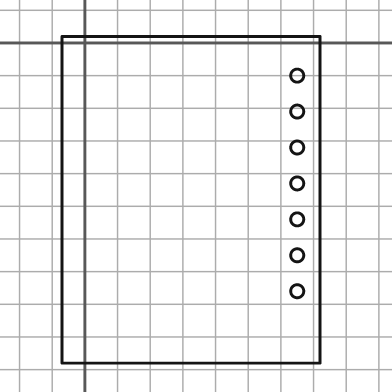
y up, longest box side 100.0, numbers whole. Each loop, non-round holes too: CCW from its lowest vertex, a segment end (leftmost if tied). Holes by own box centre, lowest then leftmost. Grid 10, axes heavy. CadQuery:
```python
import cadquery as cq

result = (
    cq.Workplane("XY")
    .moveTo(-7.0, -98.0)
    .lineTo(72.0, -98.0)
    .lineTo(72.0, 2.0)
    .lineTo(-7.0, 2.0)
    .close()
    .moveTo(65.0, -76.0)
    .circle(2.0)
    .moveTo(65.0, -65.0)
    .circle(2.0)
    .moveTo(65.0, -54.0)
    .circle(2.0)
    .moveTo(65.0, -43.0)
    .circle(2.0)
    .moveTo(65.0, -32.0)
    .circle(2.0)
    .moveTo(65.0, -21.0)
    .circle(2.0)
    .moveTo(65.0, -10.0)
    .circle(2.0)
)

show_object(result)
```